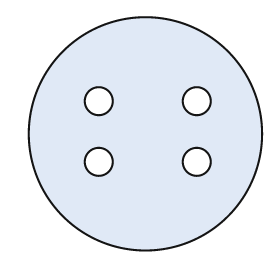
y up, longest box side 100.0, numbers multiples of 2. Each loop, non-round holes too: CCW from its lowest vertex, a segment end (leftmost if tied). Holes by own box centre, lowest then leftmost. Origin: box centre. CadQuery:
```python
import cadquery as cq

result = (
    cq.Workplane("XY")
    .moveTo(0.0, 0.0)
    .circle(50.0)
    .moveTo(-20.0, -12.0)
    .circle(6.0)
    .moveTo(22.0, -12.0)
    .circle(6.0)
    .moveTo(-20.0, 14.0)
    .circle(6.0)
    .moveTo(22.0, 14.0)
    .circle(6.0)
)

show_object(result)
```